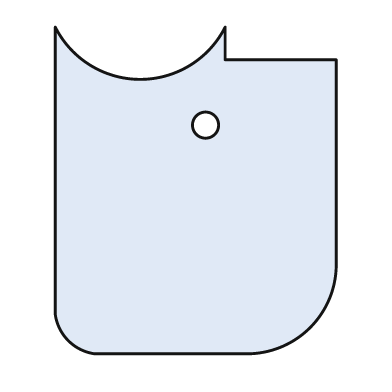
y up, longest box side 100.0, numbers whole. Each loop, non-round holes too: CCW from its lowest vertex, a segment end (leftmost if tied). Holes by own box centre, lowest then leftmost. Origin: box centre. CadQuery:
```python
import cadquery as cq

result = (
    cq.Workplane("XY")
    .moveTo(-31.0, -50.0)
    .lineTo(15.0, -50.0)
    .threePointArc((35.0, -42.0), (43.0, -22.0))
    .lineTo(43.0, 40.0)
    .lineTo(9.0, 40.0)
    .lineTo(9.0, 50.0)
    .threePointArc((-17.0, 34.0), (-43.0, 50.0))
    .lineTo(-43.0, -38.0)
    .threePointArc((-39.0, -46.0), (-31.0, -50.0))
    .close()
    .moveTo(3.0, 20.0)
    .circle(4.0)
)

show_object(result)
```